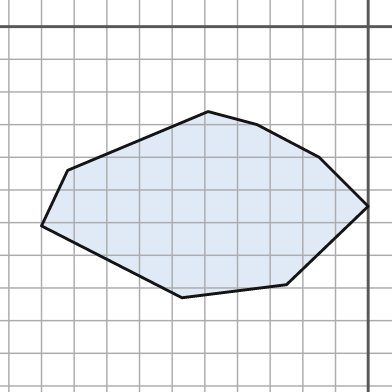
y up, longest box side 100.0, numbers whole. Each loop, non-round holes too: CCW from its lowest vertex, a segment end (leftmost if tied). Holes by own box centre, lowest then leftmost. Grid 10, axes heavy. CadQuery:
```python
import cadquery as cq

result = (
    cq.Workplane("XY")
    .moveTo(-57.0, -83.0)
    .lineTo(-25.0, -79.0)
    .lineTo(0.0, -55.0)
    .lineTo(-15.0, -40.0)
    .lineTo(-34.0, -30.0)
    .lineTo(-49.0, -26.0)
    .lineTo(-92.0, -44.0)
    .lineTo(-100.0, -61.0)
    .close()
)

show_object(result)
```